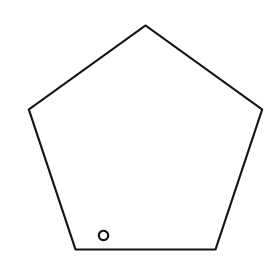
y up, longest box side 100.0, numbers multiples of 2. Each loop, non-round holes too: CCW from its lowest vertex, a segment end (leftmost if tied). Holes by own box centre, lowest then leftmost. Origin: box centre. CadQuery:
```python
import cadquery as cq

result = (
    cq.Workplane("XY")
    .moveTo(-30.0, -48.0)
    .lineTo(30.0, -48.0)
    .lineTo(50.0, 12.0)
    .lineTo(0.0, 48.0)
    .lineTo(-50.0, 12.0)
    .close()
    .moveTo(-18.0, -42.0)
    .circle(2.0)
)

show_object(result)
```